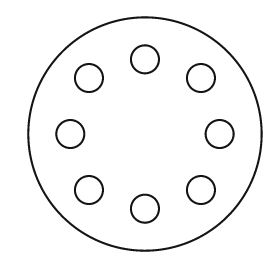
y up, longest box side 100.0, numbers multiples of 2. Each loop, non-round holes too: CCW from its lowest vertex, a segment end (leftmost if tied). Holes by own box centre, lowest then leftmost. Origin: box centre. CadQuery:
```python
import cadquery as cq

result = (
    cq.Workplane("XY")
    .moveTo(0.0, 0.0)
    .circle(50.0)
    .moveTo(0.0, -32.0)
    .circle(6.0)
    .moveTo(-24.0, -24.0)
    .circle(6.0)
    .moveTo(24.0, -24.0)
    .circle(6.0)
    .moveTo(-32.0, 0.0)
    .circle(6.0)
    .moveTo(32.0, 0.0)
    .circle(6.0)
    .moveTo(-24.0, 24.0)
    .circle(6.0)
    .moveTo(24.0, 24.0)
    .circle(6.0)
    .moveTo(0.0, 32.0)
    .circle(6.0)
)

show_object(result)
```